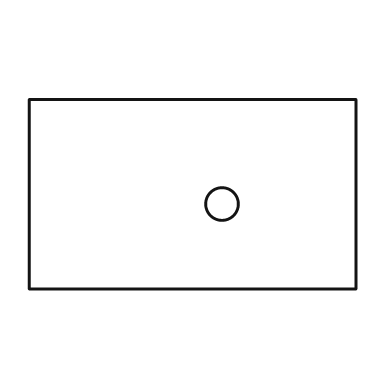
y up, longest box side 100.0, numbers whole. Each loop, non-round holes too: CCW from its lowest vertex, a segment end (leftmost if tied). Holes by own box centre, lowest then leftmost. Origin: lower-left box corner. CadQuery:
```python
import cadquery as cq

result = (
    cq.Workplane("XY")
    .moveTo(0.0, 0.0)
    .lineTo(100.0, 0.0)
    .lineTo(100.0, 58.0)
    .lineTo(0.0, 58.0)
    .close()
    .moveTo(59.0, 26.0)
    .circle(5.0)
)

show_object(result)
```